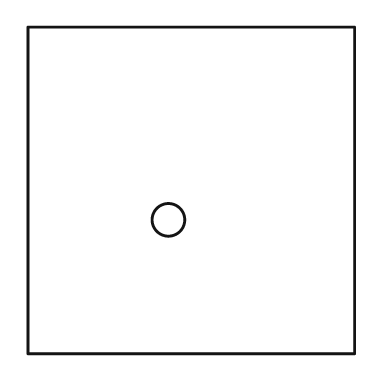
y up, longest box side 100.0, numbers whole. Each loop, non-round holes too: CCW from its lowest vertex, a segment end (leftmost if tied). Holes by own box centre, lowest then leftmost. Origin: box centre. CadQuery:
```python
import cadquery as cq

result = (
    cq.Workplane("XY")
    .moveTo(-50.0, -50.0)
    .lineTo(50.0, -50.0)
    .lineTo(50.0, 50.0)
    .lineTo(-50.0, 50.0)
    .close()
    .moveTo(-7.0, -9.0)
    .circle(5.0)
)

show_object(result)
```